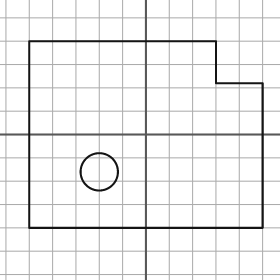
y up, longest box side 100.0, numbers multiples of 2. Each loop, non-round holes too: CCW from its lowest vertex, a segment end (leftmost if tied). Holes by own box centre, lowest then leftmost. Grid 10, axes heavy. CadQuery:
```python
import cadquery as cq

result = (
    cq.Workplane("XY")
    .moveTo(-50.0, -40.0)
    .lineTo(50.0, -40.0)
    .lineTo(50.0, 22.0)
    .lineTo(30.0, 22.0)
    .lineTo(30.0, 40.0)
    .lineTo(-50.0, 40.0)
    .close()
    .moveTo(-20.0, -16.0)
    .circle(8.0)
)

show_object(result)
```